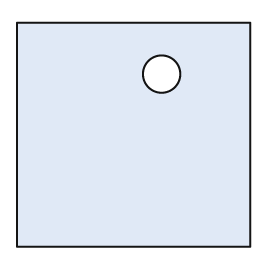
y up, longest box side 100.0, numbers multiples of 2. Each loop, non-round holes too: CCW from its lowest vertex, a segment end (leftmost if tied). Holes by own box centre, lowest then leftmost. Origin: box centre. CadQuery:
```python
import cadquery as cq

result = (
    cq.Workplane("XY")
    .moveTo(-50.0, -48.0)
    .lineTo(50.0, -48.0)
    .lineTo(50.0, 48.0)
    .lineTo(-50.0, 48.0)
    .close()
    .moveTo(12.0, 26.0)
    .circle(8.0)
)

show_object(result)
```